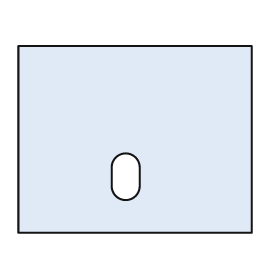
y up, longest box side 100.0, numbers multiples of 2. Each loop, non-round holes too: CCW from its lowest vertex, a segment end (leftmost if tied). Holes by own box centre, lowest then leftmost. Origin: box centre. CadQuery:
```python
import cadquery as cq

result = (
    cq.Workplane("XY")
    .moveTo(-50.0, -40.0)
    .lineTo(50.0, -40.0)
    .lineTo(50.0, 40.0)
    .lineTo(-50.0, 40.0)
    .close()
    .moveTo(-10.0, -20.0)
    .threePointArc((-4.0, -26.0), (2.0, -20.0))
    .lineTo(2.0, -12.0)
    .threePointArc((-4.0, -6.0), (-10.0, -12.0))
    .close()
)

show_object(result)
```